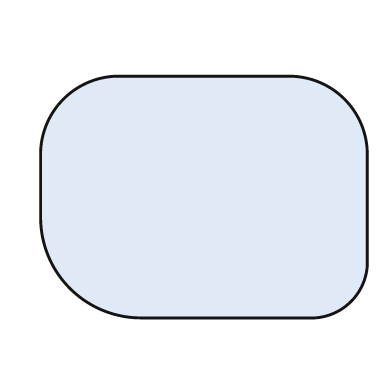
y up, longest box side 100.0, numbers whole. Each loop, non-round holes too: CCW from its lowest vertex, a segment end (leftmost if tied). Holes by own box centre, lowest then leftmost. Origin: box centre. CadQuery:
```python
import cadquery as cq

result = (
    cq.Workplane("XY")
    .moveTo(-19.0, -37.0)
    .lineTo(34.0, -37.0)
    .threePointArc((45.0, -32.0), (50.0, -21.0))
    .lineTo(50.0, 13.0)
    .threePointArc((43.0, 30.0), (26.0, 37.0))
    .lineTo(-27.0, 37.0)
    .threePointArc((-43.0, 30.0), (-50.0, 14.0))
    .lineTo(-50.0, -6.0)
    .threePointArc((-41.0, -28.0), (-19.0, -37.0))
    .close()
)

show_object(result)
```